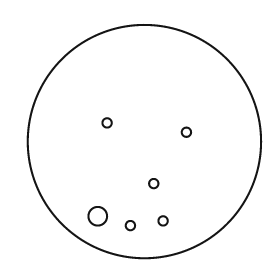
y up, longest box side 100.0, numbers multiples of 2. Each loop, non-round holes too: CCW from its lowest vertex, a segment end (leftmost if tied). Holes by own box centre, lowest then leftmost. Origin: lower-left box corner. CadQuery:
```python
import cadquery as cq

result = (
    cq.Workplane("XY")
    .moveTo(50.0, 50.0)
    .circle(50.0)
    .moveTo(44.0, 14.0)
    .circle(2.0)
    .moveTo(58.0, 16.0)
    .circle(2.0)
    .moveTo(30.0, 18.0)
    .circle(4.0)
    .moveTo(54.0, 32.0)
    .circle(2.0)
    .moveTo(68.0, 54.0)
    .circle(2.0)
    .moveTo(34.0, 58.0)
    .circle(2.0)
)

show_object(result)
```